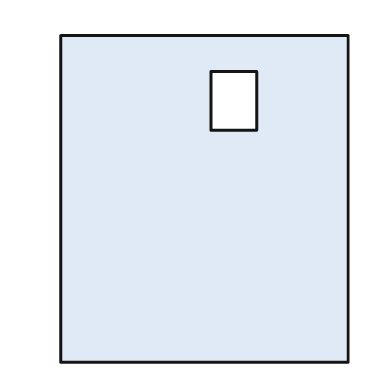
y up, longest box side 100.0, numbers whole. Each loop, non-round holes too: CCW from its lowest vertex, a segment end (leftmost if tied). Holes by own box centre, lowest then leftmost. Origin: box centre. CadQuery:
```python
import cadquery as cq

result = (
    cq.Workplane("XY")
    .moveTo(-44.0, -50.0)
    .lineTo(44.0, -50.0)
    .lineTo(44.0, 50.0)
    .lineTo(-44.0, 50.0)
    .close()
    .moveTo(2.0, 21.0)
    .lineTo(16.0, 21.0)
    .lineTo(16.0, 39.0)
    .lineTo(2.0, 39.0)
    .close()
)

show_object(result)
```